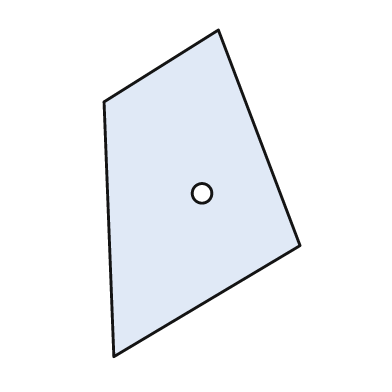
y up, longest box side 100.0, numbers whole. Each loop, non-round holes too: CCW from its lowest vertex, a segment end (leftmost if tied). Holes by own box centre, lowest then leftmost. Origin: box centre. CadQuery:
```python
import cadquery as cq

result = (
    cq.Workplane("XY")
    .moveTo(-27.0, -50.0)
    .lineTo(30.0, -16.0)
    .lineTo(5.0, 50.0)
    .lineTo(-30.0, 28.0)
    .close()
    .moveTo(0.0, 0.0)
    .circle(3.0)
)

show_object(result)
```